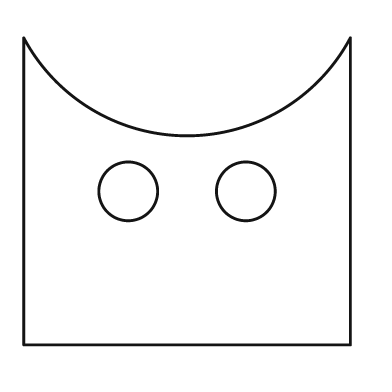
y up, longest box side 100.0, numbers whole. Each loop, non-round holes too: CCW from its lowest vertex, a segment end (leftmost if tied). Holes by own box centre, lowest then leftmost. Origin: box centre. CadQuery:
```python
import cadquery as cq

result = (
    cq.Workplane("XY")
    .moveTo(-50.0, -47.0)
    .lineTo(50.0, -47.0)
    .lineTo(50.0, 47.0)
    .threePointArc((0.0, 17.0), (-50.0, 47.0))
    .close()
    .moveTo(-18.0, 0.0)
    .circle(9.0)
    .moveTo(18.0, 0.0)
    .circle(9.0)
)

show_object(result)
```